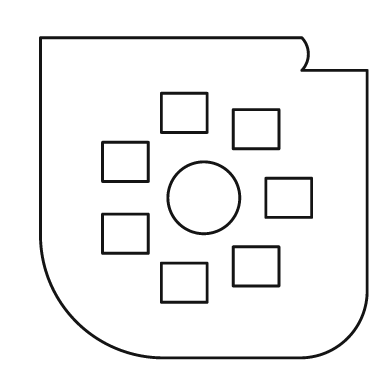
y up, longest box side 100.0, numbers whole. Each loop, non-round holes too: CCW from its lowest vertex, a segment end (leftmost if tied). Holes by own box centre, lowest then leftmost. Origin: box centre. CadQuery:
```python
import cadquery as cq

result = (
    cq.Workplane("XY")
    .moveTo(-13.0, -49.0)
    .lineTo(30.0, -49.0)
    .threePointArc((44.0, -43.0), (50.0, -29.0))
    .lineTo(50.0, 39.0)
    .lineTo(30.0, 39.0)
    .threePointArc((32.0, 44.0), (30.0, 49.0))
    .lineTo(-50.0, 49.0)
    .lineTo(-50.0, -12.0)
    .threePointArc((-39.0, -38.0), (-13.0, -49.0))
    .close()
    .moveTo(-13.0, -32.0)
    .lineTo(1.0, -32.0)
    .lineTo(1.0, -20.0)
    .lineTo(-13.0, -20.0)
    .close()
    .moveTo(9.0, -27.0)
    .lineTo(23.0, -27.0)
    .lineTo(23.0, -15.0)
    .lineTo(9.0, -15.0)
    .close()
    .moveTo(-31.0, -17.0)
    .lineTo(-17.0, -17.0)
    .lineTo(-17.0, -5.0)
    .lineTo(-31.0, -5.0)
    .close()
    .moveTo(0.0, 0.0)
    .circle(11.0)
    .moveTo(19.0, -6.0)
    .lineTo(33.0, -6.0)
    .lineTo(33.0, 6.0)
    .lineTo(19.0, 6.0)
    .close()
    .moveTo(-31.0, 5.0)
    .lineTo(-17.0, 5.0)
    .lineTo(-17.0, 17.0)
    .lineTo(-31.0, 17.0)
    .close()
    .moveTo(9.0, 15.0)
    .lineTo(23.0, 15.0)
    .lineTo(23.0, 27.0)
    .lineTo(9.0, 27.0)
    .close()
    .moveTo(-13.0, 20.0)
    .lineTo(1.0, 20.0)
    .lineTo(1.0, 32.0)
    .lineTo(-13.0, 32.0)
    .close()
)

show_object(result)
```